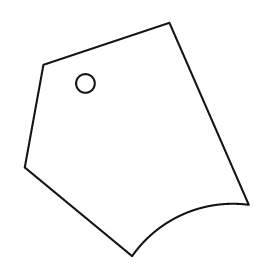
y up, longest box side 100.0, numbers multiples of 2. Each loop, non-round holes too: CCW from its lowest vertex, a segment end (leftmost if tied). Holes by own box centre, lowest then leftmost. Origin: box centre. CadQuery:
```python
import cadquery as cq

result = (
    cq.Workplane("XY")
    .moveTo(-2.0, -50.0)
    .threePointArc((20.0, -32.0), (48.0, -28.0))
    .lineTo(14.0, 50.0)
    .lineTo(-40.0, 32.0)
    .lineTo(-48.0, -12.0)
    .close()
    .moveTo(-22.0, 24.0)
    .circle(4.0)
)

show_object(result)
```